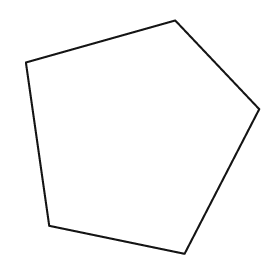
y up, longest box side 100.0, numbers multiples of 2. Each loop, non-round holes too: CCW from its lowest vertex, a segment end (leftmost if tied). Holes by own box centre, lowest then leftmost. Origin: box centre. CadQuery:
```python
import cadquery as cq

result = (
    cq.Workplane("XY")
    .moveTo(18.0, -50.0)
    .lineTo(50.0, 12.0)
    .lineTo(14.0, 50.0)
    .lineTo(-50.0, 32.0)
    .lineTo(-40.0, -38.0)
    .close()
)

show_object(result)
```